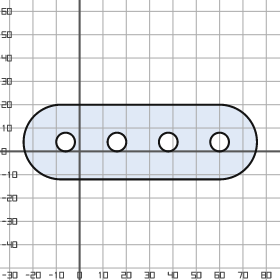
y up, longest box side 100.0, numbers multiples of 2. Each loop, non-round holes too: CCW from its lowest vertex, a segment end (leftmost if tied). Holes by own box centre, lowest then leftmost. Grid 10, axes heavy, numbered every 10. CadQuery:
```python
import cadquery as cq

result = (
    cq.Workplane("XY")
    .moveTo(-8.0, -12.0)
    .lineTo(60.0, -12.0)
    .threePointArc((76.0, 4.0), (60.0, 20.0))
    .lineTo(-8.0, 20.0)
    .threePointArc((-24.0, 4.0), (-8.0, -12.0))
    .close()
    .moveTo(-6.0, 4.0)
    .circle(4.0)
    .moveTo(16.0, 4.0)
    .circle(4.0)
    .moveTo(38.0, 4.0)
    .circle(4.0)
    .moveTo(60.0, 4.0)
    .circle(4.0)
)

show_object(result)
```